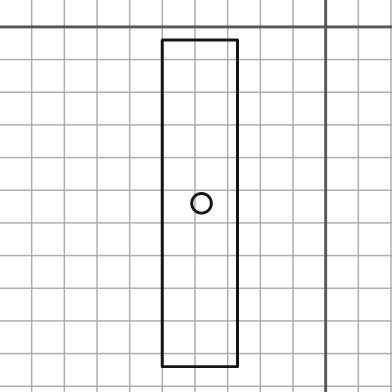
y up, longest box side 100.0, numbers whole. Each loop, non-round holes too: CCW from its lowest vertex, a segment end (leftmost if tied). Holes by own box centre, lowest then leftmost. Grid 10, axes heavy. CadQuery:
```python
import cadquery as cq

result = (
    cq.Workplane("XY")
    .moveTo(-50.0, -104.0)
    .lineTo(-27.0, -104.0)
    .lineTo(-27.0, -4.0)
    .lineTo(-50.0, -4.0)
    .close()
    .moveTo(-38.0, -54.0)
    .circle(3.0)
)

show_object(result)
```